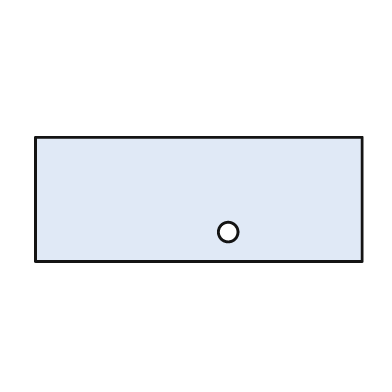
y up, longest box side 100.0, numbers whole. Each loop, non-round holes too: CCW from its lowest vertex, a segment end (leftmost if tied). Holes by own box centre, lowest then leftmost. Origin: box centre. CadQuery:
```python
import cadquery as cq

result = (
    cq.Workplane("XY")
    .moveTo(-50.0, -19.0)
    .lineTo(50.0, -19.0)
    .lineTo(50.0, 19.0)
    .lineTo(-50.0, 19.0)
    .close()
    .moveTo(9.0, -10.0)
    .circle(3.0)
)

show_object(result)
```